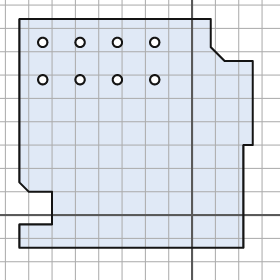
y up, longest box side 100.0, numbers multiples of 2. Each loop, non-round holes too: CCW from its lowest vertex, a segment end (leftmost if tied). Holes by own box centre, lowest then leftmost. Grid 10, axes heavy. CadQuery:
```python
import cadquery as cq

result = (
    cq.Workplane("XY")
    .moveTo(-74.0, -14.0)
    .lineTo(22.0, -14.0)
    .lineTo(22.0, 30.0)
    .lineTo(26.0, 30.0)
    .lineTo(26.0, 66.0)
    .lineTo(14.0, 66.0)
    .lineTo(8.0, 72.0)
    .lineTo(8.0, 84.0)
    .lineTo(-74.0, 84.0)
    .lineTo(-74.0, 14.0)
    .lineTo(-70.0, 10.0)
    .lineTo(-60.0, 10.0)
    .lineTo(-60.0, -4.0)
    .lineTo(-74.0, -4.0)
    .close()
    .moveTo(-64.0, 58.0)
    .circle(2.0)
    .moveTo(-48.0, 58.0)
    .circle(2.0)
    .moveTo(-32.0, 58.0)
    .circle(2.0)
    .moveTo(-16.0, 58.0)
    .circle(2.0)
    .moveTo(-64.0, 74.0)
    .circle(2.0)
    .moveTo(-48.0, 74.0)
    .circle(2.0)
    .moveTo(-32.0, 74.0)
    .circle(2.0)
    .moveTo(-16.0, 74.0)
    .circle(2.0)
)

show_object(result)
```